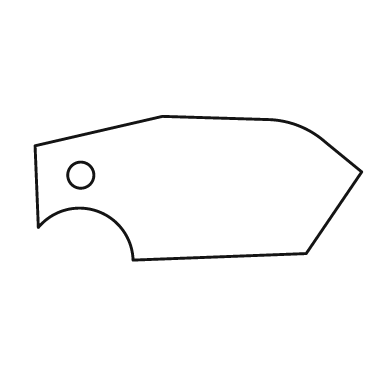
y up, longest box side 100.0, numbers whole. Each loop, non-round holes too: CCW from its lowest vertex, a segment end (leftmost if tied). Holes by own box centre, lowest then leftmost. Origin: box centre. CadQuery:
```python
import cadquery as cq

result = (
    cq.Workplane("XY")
    .moveTo(-20.0, -22.0)
    .lineTo(33.0, -20.0)
    .lineTo(50.0, 5.0)
    .lineTo(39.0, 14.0)
    .threePointArc((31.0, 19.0), (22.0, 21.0))
    .lineTo(-11.0, 22.0)
    .lineTo(-50.0, 13.0)
    .lineTo(-49.0, -12.0)
    .threePointArc((-31.0, -7.0), (-20.0, -22.0))
    .close()
    .moveTo(-36.0, 4.0)
    .circle(4.0)
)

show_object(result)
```